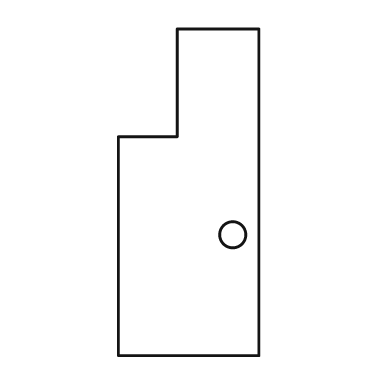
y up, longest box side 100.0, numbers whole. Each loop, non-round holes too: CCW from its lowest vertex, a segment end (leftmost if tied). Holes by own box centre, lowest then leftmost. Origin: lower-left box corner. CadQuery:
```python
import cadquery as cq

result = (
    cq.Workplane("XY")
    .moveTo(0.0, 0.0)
    .lineTo(43.0, 0.0)
    .lineTo(43.0, 100.0)
    .lineTo(18.0, 100.0)
    .lineTo(18.0, 67.0)
    .lineTo(0.0, 67.0)
    .close()
    .moveTo(35.0, 37.0)
    .circle(4.0)
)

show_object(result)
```